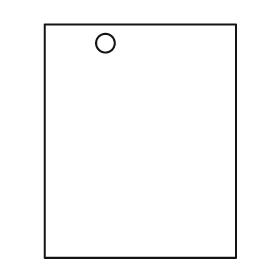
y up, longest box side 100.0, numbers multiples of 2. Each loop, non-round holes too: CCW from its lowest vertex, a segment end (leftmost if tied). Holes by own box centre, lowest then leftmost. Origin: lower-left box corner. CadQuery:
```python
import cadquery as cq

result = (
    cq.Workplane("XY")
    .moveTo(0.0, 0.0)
    .lineTo(82.0, 0.0)
    .lineTo(82.0, 100.0)
    .lineTo(0.0, 100.0)
    .close()
    .moveTo(26.0, 92.0)
    .circle(4.0)
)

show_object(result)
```